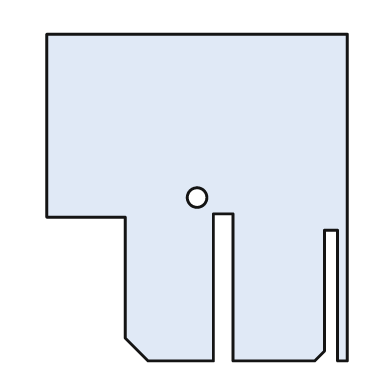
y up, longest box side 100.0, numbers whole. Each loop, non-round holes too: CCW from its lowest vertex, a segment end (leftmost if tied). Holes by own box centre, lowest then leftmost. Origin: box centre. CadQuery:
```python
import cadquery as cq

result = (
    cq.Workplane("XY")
    .moveTo(-15.0, -50.0)
    .lineTo(5.0, -50.0)
    .lineTo(5.0, -5.0)
    .lineTo(11.0, -5.0)
    .lineTo(11.0, -50.0)
    .lineTo(36.0, -50.0)
    .lineTo(39.0, -47.0)
    .lineTo(39.0, -10.0)
    .lineTo(43.0, -10.0)
    .lineTo(43.0, -50.0)
    .lineTo(46.0, -50.0)
    .lineTo(46.0, 50.0)
    .lineTo(-46.0, 50.0)
    .lineTo(-46.0, -6.0)
    .lineTo(-22.0, -6.0)
    .lineTo(-22.0, -43.0)
    .close()
    .moveTo(0.0, 0.0)
    .circle(3.0)
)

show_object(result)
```